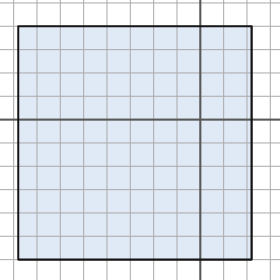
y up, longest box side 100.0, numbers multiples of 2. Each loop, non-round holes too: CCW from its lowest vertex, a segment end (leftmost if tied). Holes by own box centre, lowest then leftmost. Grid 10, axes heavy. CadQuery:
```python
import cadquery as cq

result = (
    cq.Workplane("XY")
    .moveTo(-78.0, -60.0)
    .lineTo(22.0, -60.0)
    .lineTo(22.0, 40.0)
    .lineTo(-78.0, 40.0)
    .close()
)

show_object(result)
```